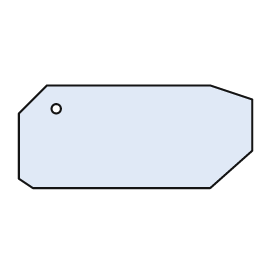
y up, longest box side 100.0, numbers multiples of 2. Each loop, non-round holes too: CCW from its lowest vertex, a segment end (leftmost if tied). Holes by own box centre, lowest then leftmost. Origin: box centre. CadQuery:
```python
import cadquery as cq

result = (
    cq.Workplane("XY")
    .moveTo(-44.0, -22.0)
    .lineTo(32.0, -22.0)
    .lineTo(50.0, -6.0)
    .lineTo(50.0, 16.0)
    .lineTo(32.0, 22.0)
    .lineTo(-38.0, 22.0)
    .lineTo(-50.0, 10.0)
    .lineTo(-50.0, -18.0)
    .close()
    .moveTo(-34.0, 12.0)
    .circle(2.0)
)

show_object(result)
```